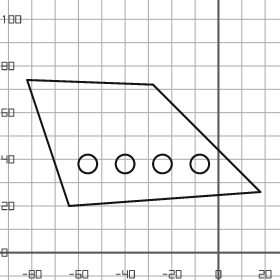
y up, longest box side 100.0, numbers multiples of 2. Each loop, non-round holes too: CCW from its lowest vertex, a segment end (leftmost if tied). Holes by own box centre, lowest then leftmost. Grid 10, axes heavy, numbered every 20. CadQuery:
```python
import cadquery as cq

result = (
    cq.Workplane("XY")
    .moveTo(-64.0, 20.0)
    .lineTo(18.0, 26.0)
    .lineTo(-28.0, 72.0)
    .lineTo(-82.0, 74.0)
    .close()
    .moveTo(-56.0, 38.0)
    .circle(4.0)
    .moveTo(-40.0, 38.0)
    .circle(4.0)
    .moveTo(-24.0, 38.0)
    .circle(4.0)
    .moveTo(-8.0, 38.0)
    .circle(4.0)
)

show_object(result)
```